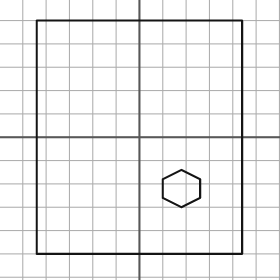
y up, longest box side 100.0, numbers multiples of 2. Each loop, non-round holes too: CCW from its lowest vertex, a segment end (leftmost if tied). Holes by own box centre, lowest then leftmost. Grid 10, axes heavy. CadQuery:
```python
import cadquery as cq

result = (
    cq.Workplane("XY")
    .moveTo(-44.0, -50.0)
    .lineTo(44.0, -50.0)
    .lineTo(44.0, 50.0)
    .lineTo(-44.0, 50.0)
    .close()
    .moveTo(18.0, -30.0)
    .lineTo(26.0, -26.0)
    .lineTo(26.0, -18.0)
    .lineTo(18.0, -14.0)
    .lineTo(10.0, -18.0)
    .lineTo(10.0, -26.0)
    .close()
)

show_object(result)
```